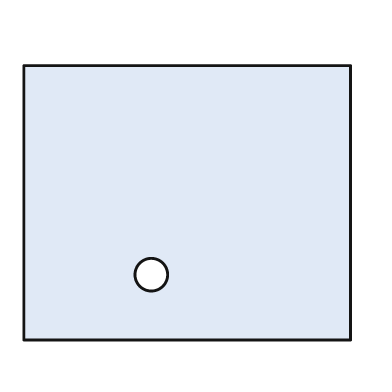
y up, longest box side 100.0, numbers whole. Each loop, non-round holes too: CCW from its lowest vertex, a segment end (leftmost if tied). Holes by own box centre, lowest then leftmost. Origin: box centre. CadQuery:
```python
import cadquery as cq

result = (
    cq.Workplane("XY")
    .moveTo(-50.0, -42.0)
    .lineTo(50.0, -42.0)
    .lineTo(50.0, 42.0)
    .lineTo(-50.0, 42.0)
    .close()
    .moveTo(-11.0, -22.0)
    .circle(5.0)
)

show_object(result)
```